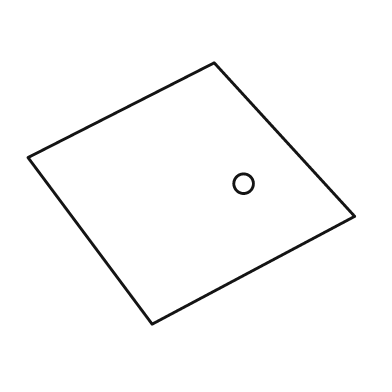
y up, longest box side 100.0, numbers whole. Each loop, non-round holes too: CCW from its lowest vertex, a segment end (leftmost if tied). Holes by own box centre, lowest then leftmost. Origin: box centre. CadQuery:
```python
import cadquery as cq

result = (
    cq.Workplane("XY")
    .moveTo(-12.0, -40.0)
    .lineTo(50.0, -7.0)
    .lineTo(7.0, 40.0)
    .lineTo(-50.0, 11.0)
    .close()
    .moveTo(16.0, 3.0)
    .circle(3.0)
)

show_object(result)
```